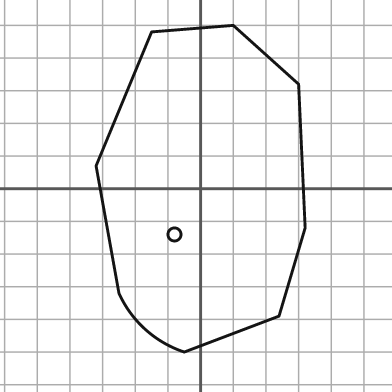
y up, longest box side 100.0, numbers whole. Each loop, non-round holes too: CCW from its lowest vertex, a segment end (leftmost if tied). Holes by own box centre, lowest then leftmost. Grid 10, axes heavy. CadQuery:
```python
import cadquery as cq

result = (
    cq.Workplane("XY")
    .moveTo(-5.0, -50.0)
    .lineTo(24.0, -39.0)
    .lineTo(32.0, -12.0)
    .lineTo(30.0, 32.0)
    .lineTo(10.0, 50.0)
    .lineTo(-15.0, 48.0)
    .lineTo(-32.0, 7.0)
    .lineTo(-25.0, -32.0)
    .threePointArc((-17.0, -43.0), (-5.0, -50.0))
    .close()
    .moveTo(-8.0, -14.0)
    .circle(2.0)
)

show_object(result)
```